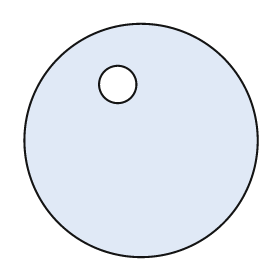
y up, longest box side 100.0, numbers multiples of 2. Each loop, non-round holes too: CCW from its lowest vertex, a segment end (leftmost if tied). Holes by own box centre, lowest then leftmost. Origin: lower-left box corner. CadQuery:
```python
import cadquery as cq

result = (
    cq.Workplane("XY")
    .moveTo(50.0, 50.0)
    .circle(50.0)
    .moveTo(40.0, 74.0)
    .circle(8.0)
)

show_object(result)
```